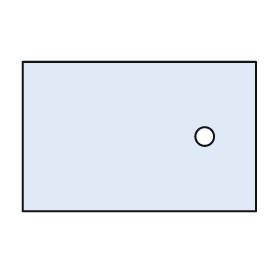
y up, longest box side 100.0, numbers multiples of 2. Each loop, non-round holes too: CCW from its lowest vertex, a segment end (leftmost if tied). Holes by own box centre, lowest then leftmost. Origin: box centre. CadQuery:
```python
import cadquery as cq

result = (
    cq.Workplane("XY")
    .moveTo(-50.0, -32.0)
    .lineTo(50.0, -32.0)
    .lineTo(50.0, 32.0)
    .lineTo(-50.0, 32.0)
    .close()
    .moveTo(28.0, 0.0)
    .circle(4.0)
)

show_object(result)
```